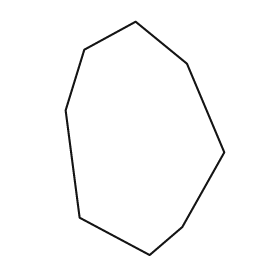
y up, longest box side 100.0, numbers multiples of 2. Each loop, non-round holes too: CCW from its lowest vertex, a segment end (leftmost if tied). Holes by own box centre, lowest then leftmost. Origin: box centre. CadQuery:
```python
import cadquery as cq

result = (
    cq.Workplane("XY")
    .moveTo(2.0, -50.0)
    .lineTo(16.0, -38.0)
    .lineTo(34.0, -6.0)
    .lineTo(18.0, 32.0)
    .lineTo(-4.0, 50.0)
    .lineTo(-26.0, 38.0)
    .lineTo(-34.0, 12.0)
    .lineTo(-28.0, -34.0)
    .close()
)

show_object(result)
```